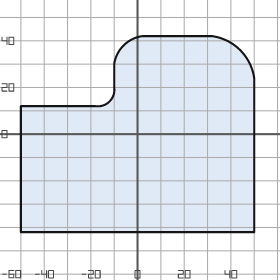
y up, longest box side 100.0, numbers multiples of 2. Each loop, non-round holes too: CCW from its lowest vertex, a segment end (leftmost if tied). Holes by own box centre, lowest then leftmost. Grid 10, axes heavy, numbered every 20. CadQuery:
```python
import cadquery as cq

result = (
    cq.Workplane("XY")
    .moveTo(-50.0, -42.0)
    .lineTo(50.0, -42.0)
    .lineTo(50.0, 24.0)
    .threePointArc((44.0, 36.0), (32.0, 42.0))
    .lineTo(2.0, 42.0)
    .threePointArc((-6.0, 38.0), (-10.0, 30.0))
    .lineTo(-10.0, 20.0)
    .threePointArc((-12.0, 14.0), (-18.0, 12.0))
    .lineTo(-50.0, 12.0)
    .close()
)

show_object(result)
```